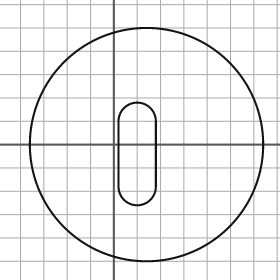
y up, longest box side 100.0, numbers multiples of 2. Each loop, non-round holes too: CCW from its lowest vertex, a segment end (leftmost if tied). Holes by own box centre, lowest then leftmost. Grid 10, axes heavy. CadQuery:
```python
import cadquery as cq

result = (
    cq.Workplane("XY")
    .moveTo(14.0, 0.0)
    .circle(50.0)
    .moveTo(2.0, -18.0)
    .threePointArc((10.0, -26.0), (18.0, -18.0))
    .lineTo(18.0, 10.0)
    .threePointArc((10.0, 18.0), (2.0, 10.0))
    .close()
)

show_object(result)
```